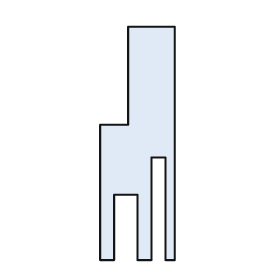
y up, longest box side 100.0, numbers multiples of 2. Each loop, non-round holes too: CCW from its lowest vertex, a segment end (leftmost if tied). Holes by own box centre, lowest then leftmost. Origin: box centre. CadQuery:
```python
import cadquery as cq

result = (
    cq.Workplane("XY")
    .moveTo(-16.0, -50.0)
    .lineTo(-10.0, -50.0)
    .lineTo(-10.0, -22.0)
    .lineTo(0.0, -22.0)
    .lineTo(0.0, -50.0)
    .lineTo(6.0, -50.0)
    .lineTo(6.0, -6.0)
    .lineTo(12.0, -6.0)
    .lineTo(12.0, -50.0)
    .lineTo(16.0, -50.0)
    .lineTo(16.0, 50.0)
    .lineTo(-4.0, 50.0)
    .lineTo(-4.0, 8.0)
    .lineTo(-16.0, 8.0)
    .close()
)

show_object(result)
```